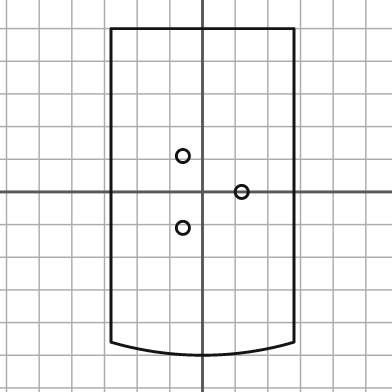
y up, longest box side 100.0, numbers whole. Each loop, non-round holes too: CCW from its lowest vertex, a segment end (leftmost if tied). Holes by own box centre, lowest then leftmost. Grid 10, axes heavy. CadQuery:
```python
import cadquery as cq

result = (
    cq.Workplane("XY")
    .moveTo(-28.0, -46.0)
    .threePointArc((0.0, -50.0), (28.0, -46.0))
    .lineTo(28.0, 50.0)
    .lineTo(-28.0, 50.0)
    .close()
    .moveTo(-6.0, -11.0)
    .circle(2.0)
    .moveTo(12.0, 0.0)
    .circle(2.0)
    .moveTo(-6.0, 11.0)
    .circle(2.0)
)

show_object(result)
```